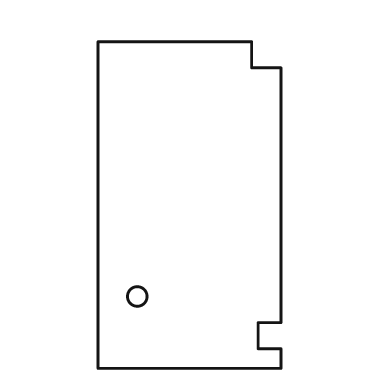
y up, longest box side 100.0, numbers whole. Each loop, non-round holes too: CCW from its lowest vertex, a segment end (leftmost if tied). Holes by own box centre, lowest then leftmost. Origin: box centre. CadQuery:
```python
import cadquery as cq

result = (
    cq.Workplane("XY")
    .moveTo(-28.0, -50.0)
    .lineTo(28.0, -50.0)
    .lineTo(28.0, -44.0)
    .lineTo(21.0, -44.0)
    .lineTo(21.0, -36.0)
    .lineTo(28.0, -36.0)
    .lineTo(28.0, 42.0)
    .lineTo(19.0, 42.0)
    .lineTo(19.0, 50.0)
    .lineTo(-28.0, 50.0)
    .close()
    .moveTo(-16.0, -28.0)
    .circle(3.0)
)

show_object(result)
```